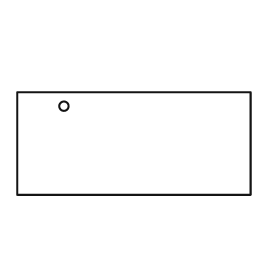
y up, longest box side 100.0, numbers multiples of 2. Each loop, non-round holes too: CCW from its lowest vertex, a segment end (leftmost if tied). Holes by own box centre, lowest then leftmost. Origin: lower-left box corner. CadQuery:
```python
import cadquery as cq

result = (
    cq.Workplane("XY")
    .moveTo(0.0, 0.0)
    .lineTo(100.0, 0.0)
    .lineTo(100.0, 44.0)
    .lineTo(0.0, 44.0)
    .close()
    .moveTo(20.0, 38.0)
    .circle(2.0)
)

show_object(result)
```